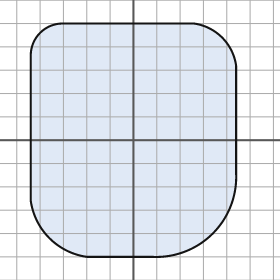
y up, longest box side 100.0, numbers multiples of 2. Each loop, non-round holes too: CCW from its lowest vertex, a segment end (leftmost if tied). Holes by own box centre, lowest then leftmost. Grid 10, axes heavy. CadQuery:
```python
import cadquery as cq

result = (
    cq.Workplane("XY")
    .moveTo(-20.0, -50.0)
    .lineTo(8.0, -50.0)
    .threePointArc((34.0, -40.0), (44.0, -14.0))
    .lineTo(44.0, 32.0)
    .threePointArc((38.0, 44.0), (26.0, 50.0))
    .lineTo(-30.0, 50.0)
    .threePointArc((-40.0, 46.0), (-44.0, 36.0))
    .lineTo(-44.0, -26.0)
    .threePointArc((-36.0, -42.0), (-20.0, -50.0))
    .close()
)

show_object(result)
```